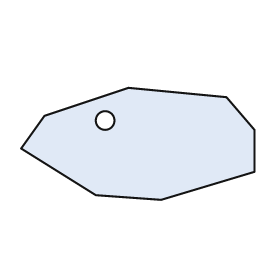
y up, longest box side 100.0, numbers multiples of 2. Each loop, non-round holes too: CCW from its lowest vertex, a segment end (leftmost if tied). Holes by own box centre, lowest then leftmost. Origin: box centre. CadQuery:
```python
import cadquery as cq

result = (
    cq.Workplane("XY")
    .moveTo(10.0, -24.0)
    .lineTo(50.0, -12.0)
    .lineTo(50.0, 6.0)
    .lineTo(38.0, 20.0)
    .lineTo(-4.0, 24.0)
    .lineTo(-40.0, 12.0)
    .lineTo(-50.0, -2.0)
    .lineTo(-18.0, -22.0)
    .close()
    .moveTo(-14.0, 10.0)
    .circle(4.0)
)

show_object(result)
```